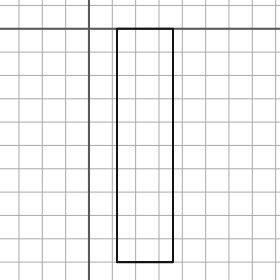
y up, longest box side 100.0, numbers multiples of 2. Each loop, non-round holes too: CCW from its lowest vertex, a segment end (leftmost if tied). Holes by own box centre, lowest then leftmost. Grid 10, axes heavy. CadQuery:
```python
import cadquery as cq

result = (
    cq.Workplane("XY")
    .moveTo(12.0, -100.0)
    .lineTo(36.0, -100.0)
    .lineTo(36.0, 0.0)
    .lineTo(12.0, 0.0)
    .close()
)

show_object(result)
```